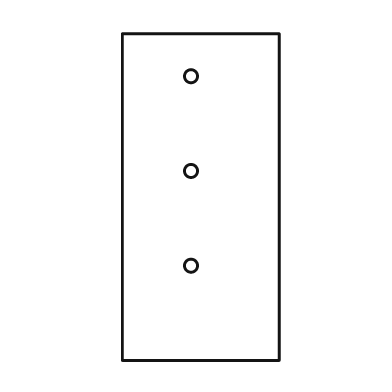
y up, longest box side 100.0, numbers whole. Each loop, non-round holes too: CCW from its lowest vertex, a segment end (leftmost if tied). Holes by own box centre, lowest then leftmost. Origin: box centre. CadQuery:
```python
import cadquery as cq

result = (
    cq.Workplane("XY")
    .moveTo(-24.0, -50.0)
    .lineTo(24.0, -50.0)
    .lineTo(24.0, 50.0)
    .lineTo(-24.0, 50.0)
    .close()
    .moveTo(-3.0, -21.0)
    .circle(2.0)
    .moveTo(-3.0, 8.0)
    .circle(2.0)
    .moveTo(-3.0, 37.0)
    .circle(2.0)
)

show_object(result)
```